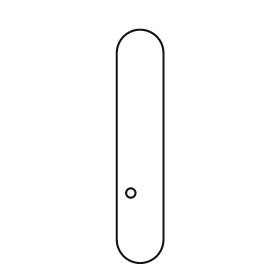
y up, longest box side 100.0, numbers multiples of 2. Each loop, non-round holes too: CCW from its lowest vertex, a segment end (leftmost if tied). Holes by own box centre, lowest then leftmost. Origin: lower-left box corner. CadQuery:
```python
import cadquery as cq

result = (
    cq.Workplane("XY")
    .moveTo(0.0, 10.0)
    .threePointArc((10.0, 0.0), (20.0, 10.0))
    .lineTo(20.0, 90.0)
    .threePointArc((10.0, 100.0), (0.0, 90.0))
    .close()
    .moveTo(6.0, 30.0)
    .circle(2.0)
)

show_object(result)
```